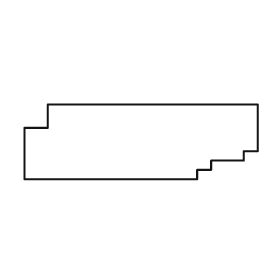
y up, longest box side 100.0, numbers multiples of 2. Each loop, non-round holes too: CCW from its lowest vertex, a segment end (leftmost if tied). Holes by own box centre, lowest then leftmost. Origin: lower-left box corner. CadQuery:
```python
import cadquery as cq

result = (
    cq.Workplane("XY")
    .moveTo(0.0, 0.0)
    .lineTo(74.0, 0.0)
    .lineTo(74.0, 4.0)
    .lineTo(80.0, 4.0)
    .lineTo(80.0, 8.0)
    .lineTo(94.0, 8.0)
    .lineTo(94.0, 12.0)
    .lineTo(100.0, 12.0)
    .lineTo(100.0, 32.0)
    .lineTo(10.0, 32.0)
    .lineTo(10.0, 22.0)
    .lineTo(0.0, 22.0)
    .close()
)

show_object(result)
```